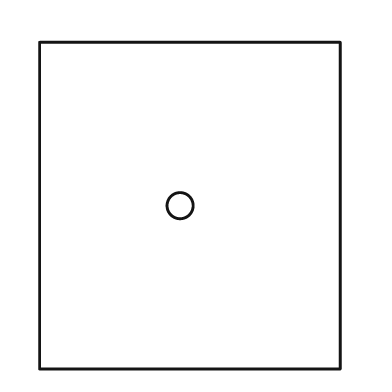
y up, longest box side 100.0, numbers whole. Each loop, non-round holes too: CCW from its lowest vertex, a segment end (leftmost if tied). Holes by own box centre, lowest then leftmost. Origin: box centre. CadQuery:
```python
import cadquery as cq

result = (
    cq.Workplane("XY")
    .moveTo(-46.0, -50.0)
    .lineTo(46.0, -50.0)
    .lineTo(46.0, 50.0)
    .lineTo(-46.0, 50.0)
    .close()
    .moveTo(-3.0, 0.0)
    .circle(4.0)
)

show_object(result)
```